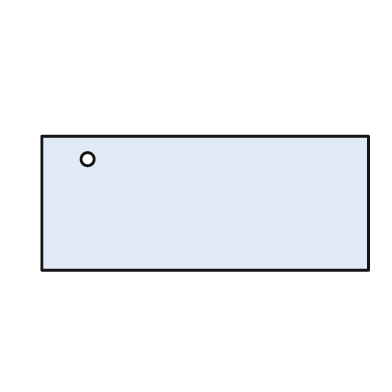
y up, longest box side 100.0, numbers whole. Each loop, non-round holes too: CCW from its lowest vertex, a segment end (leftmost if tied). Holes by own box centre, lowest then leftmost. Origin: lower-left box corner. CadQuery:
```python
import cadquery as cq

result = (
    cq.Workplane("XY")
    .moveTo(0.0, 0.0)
    .lineTo(100.0, 0.0)
    .lineTo(100.0, 41.0)
    .lineTo(0.0, 41.0)
    .close()
    .moveTo(14.0, 34.0)
    .circle(2.0)
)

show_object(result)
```